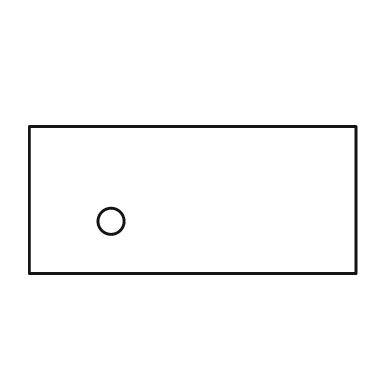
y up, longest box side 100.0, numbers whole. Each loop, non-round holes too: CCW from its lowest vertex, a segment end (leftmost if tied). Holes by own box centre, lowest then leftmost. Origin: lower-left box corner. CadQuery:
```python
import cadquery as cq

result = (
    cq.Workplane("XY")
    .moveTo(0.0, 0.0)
    .lineTo(100.0, 0.0)
    .lineTo(100.0, 45.0)
    .lineTo(0.0, 45.0)
    .close()
    .moveTo(25.0, 16.0)
    .circle(4.0)
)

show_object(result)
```